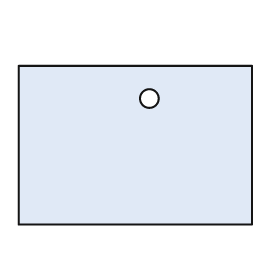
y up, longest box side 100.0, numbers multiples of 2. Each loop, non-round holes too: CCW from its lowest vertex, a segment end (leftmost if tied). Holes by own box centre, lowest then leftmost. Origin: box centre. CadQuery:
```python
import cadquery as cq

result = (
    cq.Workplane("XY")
    .moveTo(-50.0, -34.0)
    .lineTo(50.0, -34.0)
    .lineTo(50.0, 34.0)
    .lineTo(-50.0, 34.0)
    .close()
    .moveTo(6.0, 20.0)
    .circle(4.0)
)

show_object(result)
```